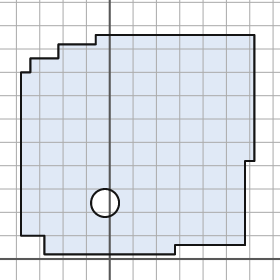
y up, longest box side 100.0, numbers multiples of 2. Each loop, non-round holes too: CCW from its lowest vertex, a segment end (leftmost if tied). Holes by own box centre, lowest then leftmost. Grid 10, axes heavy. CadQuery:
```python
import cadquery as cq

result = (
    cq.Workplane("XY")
    .moveTo(-28.0, 2.0)
    .lineTo(28.0, 2.0)
    .lineTo(28.0, 6.0)
    .lineTo(58.0, 6.0)
    .lineTo(58.0, 42.0)
    .lineTo(62.0, 42.0)
    .lineTo(62.0, 96.0)
    .lineTo(-6.0, 96.0)
    .lineTo(-6.0, 92.0)
    .lineTo(-22.0, 92.0)
    .lineTo(-22.0, 86.0)
    .lineTo(-34.0, 86.0)
    .lineTo(-34.0, 80.0)
    .lineTo(-38.0, 80.0)
    .lineTo(-38.0, 10.0)
    .lineTo(-28.0, 10.0)
    .close()
    .moveTo(-2.0, 24.0)
    .circle(6.0)
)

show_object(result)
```